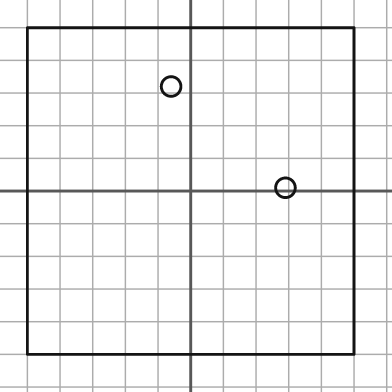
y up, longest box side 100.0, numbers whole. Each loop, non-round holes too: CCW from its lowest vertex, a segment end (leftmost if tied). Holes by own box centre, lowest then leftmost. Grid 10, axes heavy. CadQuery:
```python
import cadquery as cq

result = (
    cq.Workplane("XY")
    .moveTo(-50.0, -50.0)
    .lineTo(50.0, -50.0)
    .lineTo(50.0, 50.0)
    .lineTo(-50.0, 50.0)
    .close()
    .moveTo(29.0, 1.0)
    .circle(3.0)
    .moveTo(-6.0, 32.0)
    .circle(3.0)
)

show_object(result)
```